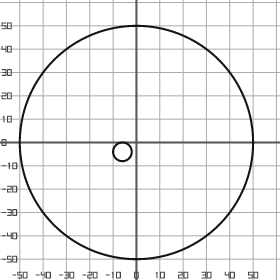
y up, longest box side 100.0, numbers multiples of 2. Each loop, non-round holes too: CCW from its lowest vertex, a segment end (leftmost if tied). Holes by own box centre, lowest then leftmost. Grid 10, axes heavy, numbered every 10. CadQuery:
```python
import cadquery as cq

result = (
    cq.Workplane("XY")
    .moveTo(0.0, 0.0)
    .circle(50.0)
    .moveTo(-6.0, -4.0)
    .circle(4.0)
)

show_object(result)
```